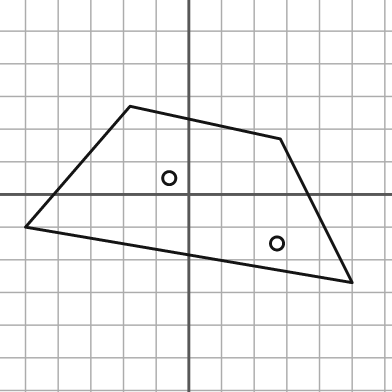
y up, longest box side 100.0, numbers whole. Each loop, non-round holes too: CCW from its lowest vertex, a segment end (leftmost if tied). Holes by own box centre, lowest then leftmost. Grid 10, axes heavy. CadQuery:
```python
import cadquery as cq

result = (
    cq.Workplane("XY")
    .moveTo(50.0, -27.0)
    .lineTo(28.0, 17.0)
    .lineTo(-18.0, 27.0)
    .lineTo(-50.0, -10.0)
    .close()
    .moveTo(27.0, -15.0)
    .circle(2.0)
    .moveTo(-6.0, 5.0)
    .circle(2.0)
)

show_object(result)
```